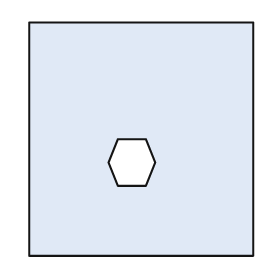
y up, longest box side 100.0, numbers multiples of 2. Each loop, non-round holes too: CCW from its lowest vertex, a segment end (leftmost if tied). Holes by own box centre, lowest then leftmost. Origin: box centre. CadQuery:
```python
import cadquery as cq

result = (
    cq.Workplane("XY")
    .moveTo(-48.0, -50.0)
    .lineTo(48.0, -50.0)
    .lineTo(48.0, 50.0)
    .lineTo(-48.0, 50.0)
    .close()
    .moveTo(-10.0, -20.0)
    .lineTo(2.0, -20.0)
    .lineTo(6.0, -10.0)
    .lineTo(2.0, 0.0)
    .lineTo(-10.0, 0.0)
    .lineTo(-14.0, -10.0)
    .close()
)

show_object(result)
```